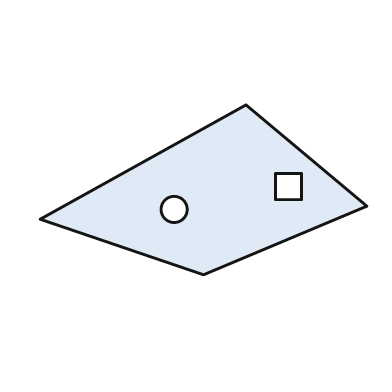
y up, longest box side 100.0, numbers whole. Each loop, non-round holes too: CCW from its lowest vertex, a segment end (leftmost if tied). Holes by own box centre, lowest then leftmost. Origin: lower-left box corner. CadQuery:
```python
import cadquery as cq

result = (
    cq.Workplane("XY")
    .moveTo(50.0, 0.0)
    .lineTo(100.0, 21.0)
    .lineTo(63.0, 52.0)
    .lineTo(0.0, 17.0)
    .close()
    .moveTo(41.0, 20.0)
    .circle(4.0)
    .moveTo(72.0, 23.0)
    .lineTo(80.0, 23.0)
    .lineTo(80.0, 31.0)
    .lineTo(72.0, 31.0)
    .close()
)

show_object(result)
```